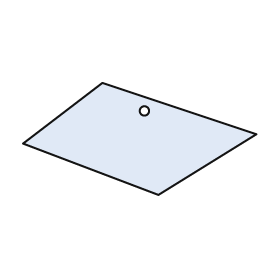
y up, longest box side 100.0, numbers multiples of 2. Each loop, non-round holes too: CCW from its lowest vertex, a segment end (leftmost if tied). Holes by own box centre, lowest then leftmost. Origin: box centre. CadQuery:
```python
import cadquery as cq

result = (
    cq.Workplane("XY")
    .moveTo(8.0, -24.0)
    .lineTo(50.0, 2.0)
    .lineTo(-16.0, 24.0)
    .lineTo(-50.0, -2.0)
    .close()
    .moveTo(2.0, 12.0)
    .circle(2.0)
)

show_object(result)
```